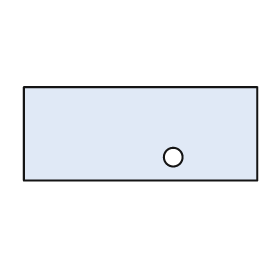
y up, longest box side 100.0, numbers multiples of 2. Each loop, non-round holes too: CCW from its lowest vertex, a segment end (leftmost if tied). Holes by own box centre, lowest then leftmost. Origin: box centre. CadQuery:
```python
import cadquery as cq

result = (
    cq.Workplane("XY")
    .moveTo(-50.0, -20.0)
    .lineTo(50.0, -20.0)
    .lineTo(50.0, 20.0)
    .lineTo(-50.0, 20.0)
    .close()
    .moveTo(14.0, -10.0)
    .circle(4.0)
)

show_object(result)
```